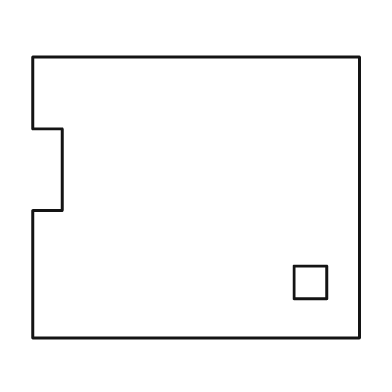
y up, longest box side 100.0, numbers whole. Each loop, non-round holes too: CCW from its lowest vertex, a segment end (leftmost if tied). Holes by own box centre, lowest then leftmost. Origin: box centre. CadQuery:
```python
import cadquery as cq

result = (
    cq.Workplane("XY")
    .moveTo(-50.0, -43.0)
    .lineTo(50.0, -43.0)
    .lineTo(50.0, 43.0)
    .lineTo(-50.0, 43.0)
    .lineTo(-50.0, 21.0)
    .lineTo(-41.0, 21.0)
    .lineTo(-41.0, -4.0)
    .lineTo(-50.0, -4.0)
    .close()
    .moveTo(30.0, -31.0)
    .lineTo(40.0, -31.0)
    .lineTo(40.0, -21.0)
    .lineTo(30.0, -21.0)
    .close()
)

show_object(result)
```